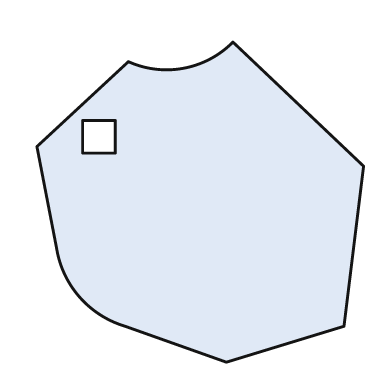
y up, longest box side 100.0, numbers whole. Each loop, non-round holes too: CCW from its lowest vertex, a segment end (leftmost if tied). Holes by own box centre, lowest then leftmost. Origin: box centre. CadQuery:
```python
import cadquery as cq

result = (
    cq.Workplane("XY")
    .moveTo(8.0, -49.0)
    .lineTo(44.0, -38.0)
    .lineTo(50.0, 11.0)
    .lineTo(10.0, 49.0)
    .threePointArc((-5.0, 41.0), (-22.0, 43.0))
    .lineTo(-50.0, 17.0)
    .lineTo(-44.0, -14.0)
    .threePointArc((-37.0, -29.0), (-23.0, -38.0))
    .close()
    .moveTo(-36.0, 15.0)
    .lineTo(-26.0, 15.0)
    .lineTo(-26.0, 25.0)
    .lineTo(-36.0, 25.0)
    .close()
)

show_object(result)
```